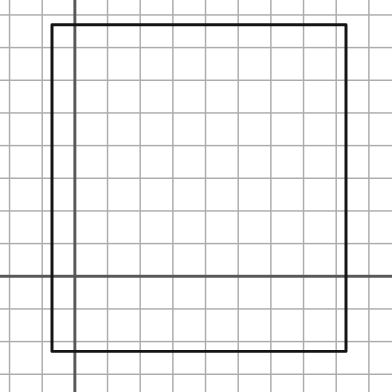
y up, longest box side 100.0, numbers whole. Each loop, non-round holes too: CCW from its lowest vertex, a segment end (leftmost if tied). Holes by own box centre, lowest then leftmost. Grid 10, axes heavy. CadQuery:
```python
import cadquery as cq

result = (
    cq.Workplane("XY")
    .moveTo(-7.0, -23.0)
    .lineTo(83.0, -23.0)
    .lineTo(83.0, 77.0)
    .lineTo(-7.0, 77.0)
    .close()
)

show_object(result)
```